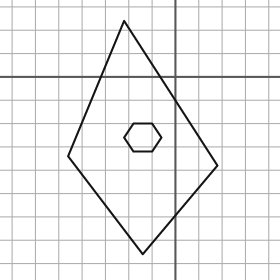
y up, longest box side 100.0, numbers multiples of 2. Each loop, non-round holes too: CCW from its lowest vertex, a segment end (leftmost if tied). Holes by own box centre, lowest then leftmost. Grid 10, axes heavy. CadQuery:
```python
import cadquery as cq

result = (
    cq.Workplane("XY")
    .moveTo(-14.0, -76.0)
    .lineTo(18.0, -38.0)
    .lineTo(-22.0, 24.0)
    .lineTo(-46.0, -34.0)
    .close()
    .moveTo(-18.0, -32.0)
    .lineTo(-10.0, -32.0)
    .lineTo(-6.0, -26.0)
    .lineTo(-10.0, -20.0)
    .lineTo(-18.0, -20.0)
    .lineTo(-22.0, -26.0)
    .close()
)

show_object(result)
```